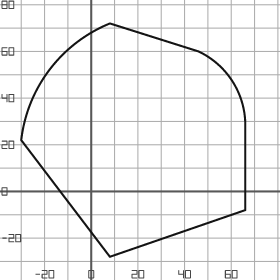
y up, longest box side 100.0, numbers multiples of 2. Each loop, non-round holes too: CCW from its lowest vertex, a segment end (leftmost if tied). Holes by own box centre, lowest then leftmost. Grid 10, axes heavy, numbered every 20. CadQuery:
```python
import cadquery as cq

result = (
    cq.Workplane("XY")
    .moveTo(8.0, -28.0)
    .lineTo(66.0, -8.0)
    .lineTo(66.0, 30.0)
    .threePointArc((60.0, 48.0), (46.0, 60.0))
    .lineTo(8.0, 72.0)
    .threePointArc((-18.0, 52.0), (-30.0, 22.0))
    .close()
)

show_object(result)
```